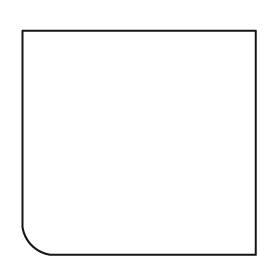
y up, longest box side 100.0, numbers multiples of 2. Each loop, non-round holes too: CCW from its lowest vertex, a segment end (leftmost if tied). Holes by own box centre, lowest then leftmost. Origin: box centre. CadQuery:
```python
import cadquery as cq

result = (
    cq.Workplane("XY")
    .moveTo(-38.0, -48.0)
    .lineTo(50.0, -48.0)
    .lineTo(50.0, 48.0)
    .lineTo(-50.0, 48.0)
    .lineTo(-50.0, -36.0)
    .threePointArc((-46.0, -44.0), (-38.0, -48.0))
    .close()
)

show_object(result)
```